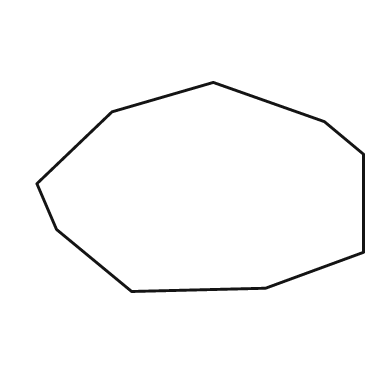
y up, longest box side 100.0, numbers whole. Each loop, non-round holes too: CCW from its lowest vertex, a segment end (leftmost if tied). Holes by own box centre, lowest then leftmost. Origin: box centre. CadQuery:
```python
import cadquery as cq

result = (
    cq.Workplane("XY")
    .moveTo(-21.0, -32.0)
    .lineTo(20.0, -31.0)
    .lineTo(50.0, -20.0)
    .lineTo(50.0, 10.0)
    .lineTo(38.0, 20.0)
    .lineTo(4.0, 32.0)
    .lineTo(-27.0, 23.0)
    .lineTo(-50.0, 1.0)
    .lineTo(-44.0, -13.0)
    .close()
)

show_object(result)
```